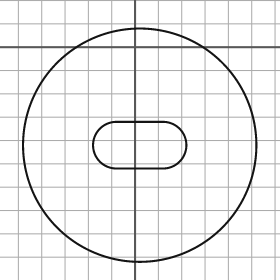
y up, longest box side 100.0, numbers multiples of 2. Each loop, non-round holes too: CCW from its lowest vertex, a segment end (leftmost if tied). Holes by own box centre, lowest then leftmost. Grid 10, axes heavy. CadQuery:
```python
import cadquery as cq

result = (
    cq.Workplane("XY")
    .moveTo(2.0, -42.0)
    .circle(50.0)
    .moveTo(-8.0, -52.0)
    .lineTo(12.0, -52.0)
    .threePointArc((22.0, -42.0), (12.0, -32.0))
    .lineTo(-8.0, -32.0)
    .threePointArc((-18.0, -42.0), (-8.0, -52.0))
    .close()
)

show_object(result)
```